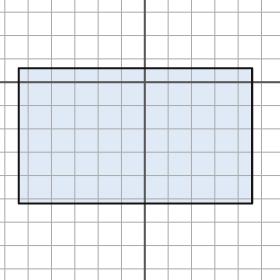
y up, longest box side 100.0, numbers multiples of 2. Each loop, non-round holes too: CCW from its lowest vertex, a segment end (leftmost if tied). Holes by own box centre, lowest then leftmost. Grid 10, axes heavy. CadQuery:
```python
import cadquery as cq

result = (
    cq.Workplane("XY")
    .moveTo(-54.0, -52.0)
    .lineTo(46.0, -52.0)
    .lineTo(46.0, 6.0)
    .lineTo(-54.0, 6.0)
    .close()
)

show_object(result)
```